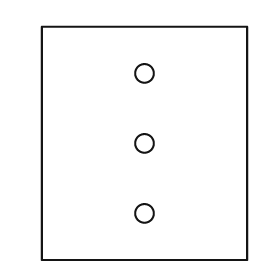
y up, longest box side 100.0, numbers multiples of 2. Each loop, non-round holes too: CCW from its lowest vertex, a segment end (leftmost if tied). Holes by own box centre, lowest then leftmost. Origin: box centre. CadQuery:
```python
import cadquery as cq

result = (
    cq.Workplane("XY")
    .moveTo(-44.0, -50.0)
    .lineTo(44.0, -50.0)
    .lineTo(44.0, 50.0)
    .lineTo(-44.0, 50.0)
    .close()
    .moveTo(0.0, -30.0)
    .circle(4.0)
    .moveTo(0.0, 0.0)
    .circle(4.0)
    .moveTo(0.0, 30.0)
    .circle(4.0)
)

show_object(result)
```